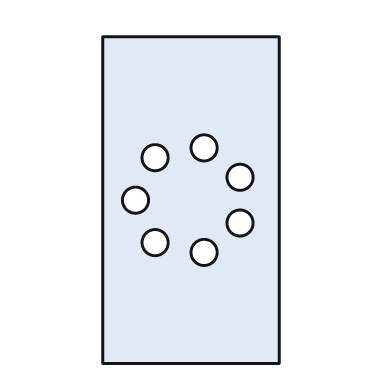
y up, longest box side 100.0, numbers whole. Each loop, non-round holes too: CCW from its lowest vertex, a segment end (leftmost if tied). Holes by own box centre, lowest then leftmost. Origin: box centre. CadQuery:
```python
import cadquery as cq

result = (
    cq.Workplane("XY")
    .moveTo(-27.0, -50.0)
    .lineTo(27.0, -50.0)
    .lineTo(27.0, 50.0)
    .lineTo(-27.0, 50.0)
    .close()
    .moveTo(4.0, -16.0)
    .circle(4.0)
    .moveTo(-11.0, -13.0)
    .circle(4.0)
    .moveTo(15.0, -7.0)
    .circle(4.0)
    .moveTo(-17.0, 0.0)
    .circle(4.0)
    .moveTo(15.0, 7.0)
    .circle(4.0)
    .moveTo(-11.0, 13.0)
    .circle(4.0)
    .moveTo(4.0, 16.0)
    .circle(4.0)
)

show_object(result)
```